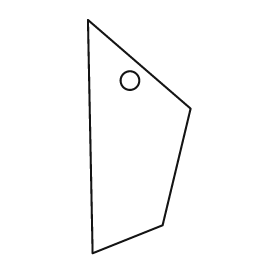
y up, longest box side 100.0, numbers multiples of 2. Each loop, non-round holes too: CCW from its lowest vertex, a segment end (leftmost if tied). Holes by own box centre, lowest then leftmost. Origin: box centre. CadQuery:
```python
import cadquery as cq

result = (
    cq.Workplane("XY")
    .moveTo(-20.0, -50.0)
    .lineTo(10.0, -38.0)
    .lineTo(22.0, 12.0)
    .lineTo(-22.0, 50.0)
    .close()
    .moveTo(-4.0, 24.0)
    .circle(4.0)
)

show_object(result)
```